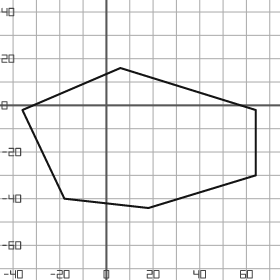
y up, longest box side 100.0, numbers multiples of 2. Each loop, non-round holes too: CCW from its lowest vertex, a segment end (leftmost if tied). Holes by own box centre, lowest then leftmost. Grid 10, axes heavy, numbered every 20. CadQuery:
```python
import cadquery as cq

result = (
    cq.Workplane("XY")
    .moveTo(18.0, -44.0)
    .lineTo(64.0, -30.0)
    .lineTo(64.0, -2.0)
    .lineTo(6.0, 16.0)
    .lineTo(-36.0, -2.0)
    .lineTo(-18.0, -40.0)
    .close()
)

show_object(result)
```